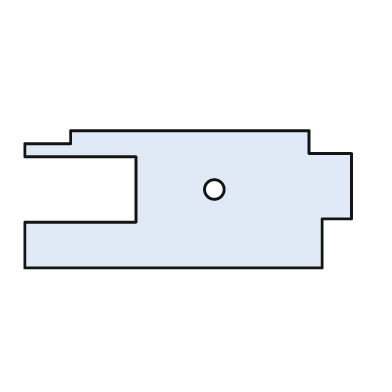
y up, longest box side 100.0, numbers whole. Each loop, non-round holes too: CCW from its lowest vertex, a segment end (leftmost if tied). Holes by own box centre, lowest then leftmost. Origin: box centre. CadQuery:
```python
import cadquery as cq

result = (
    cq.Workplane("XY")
    .moveTo(-50.0, -21.0)
    .lineTo(41.0, -21.0)
    .lineTo(41.0, -6.0)
    .lineTo(50.0, -6.0)
    .lineTo(50.0, 14.0)
    .lineTo(37.0, 14.0)
    .lineTo(37.0, 21.0)
    .lineTo(-36.0, 21.0)
    .lineTo(-36.0, 17.0)
    .lineTo(-50.0, 17.0)
    .lineTo(-50.0, 13.0)
    .lineTo(-16.0, 13.0)
    .lineTo(-16.0, -7.0)
    .lineTo(-50.0, -7.0)
    .close()
    .moveTo(8.0, 3.0)
    .circle(3.0)
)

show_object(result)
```